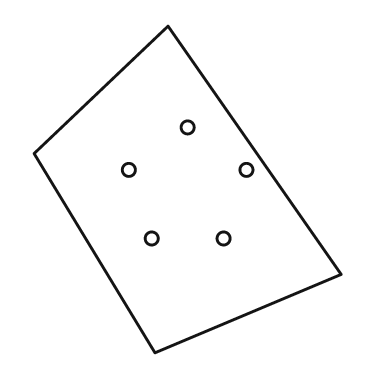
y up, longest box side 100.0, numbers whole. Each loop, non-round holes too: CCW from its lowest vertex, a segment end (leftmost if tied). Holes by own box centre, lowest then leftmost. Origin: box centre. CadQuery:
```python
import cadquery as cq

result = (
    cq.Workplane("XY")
    .moveTo(-10.0, -50.0)
    .lineTo(47.0, -26.0)
    .lineTo(-6.0, 50.0)
    .lineTo(-47.0, 11.0)
    .close()
    .moveTo(-11.0, -15.0)
    .circle(2.0)
    .moveTo(11.0, -15.0)
    .circle(2.0)
    .moveTo(-18.0, 6.0)
    .circle(2.0)
    .moveTo(18.0, 6.0)
    .circle(2.0)
    .moveTo(0.0, 19.0)
    .circle(2.0)
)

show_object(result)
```